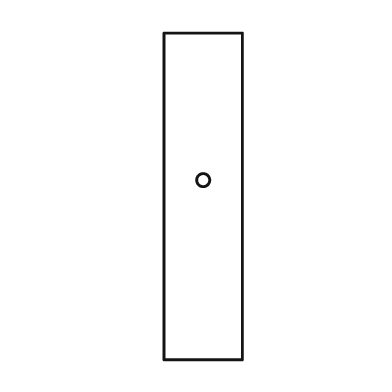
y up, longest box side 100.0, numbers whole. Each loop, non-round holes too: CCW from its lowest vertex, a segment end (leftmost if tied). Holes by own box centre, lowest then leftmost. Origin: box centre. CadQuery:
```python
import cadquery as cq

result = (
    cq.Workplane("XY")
    .moveTo(-12.0, -50.0)
    .lineTo(12.0, -50.0)
    .lineTo(12.0, 50.0)
    .lineTo(-12.0, 50.0)
    .close()
    .moveTo(0.0, 5.0)
    .circle(2.0)
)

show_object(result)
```